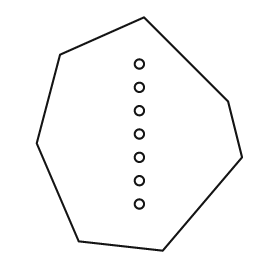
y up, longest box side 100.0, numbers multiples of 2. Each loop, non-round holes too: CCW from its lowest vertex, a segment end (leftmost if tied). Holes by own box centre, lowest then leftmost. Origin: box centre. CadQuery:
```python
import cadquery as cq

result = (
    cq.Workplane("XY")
    .moveTo(10.0, -50.0)
    .lineTo(44.0, -10.0)
    .lineTo(38.0, 14.0)
    .lineTo(2.0, 50.0)
    .lineTo(-34.0, 34.0)
    .lineTo(-44.0, -4.0)
    .lineTo(-26.0, -46.0)
    .close()
    .moveTo(0.0, -30.0)
    .circle(2.0)
    .moveTo(0.0, -20.0)
    .circle(2.0)
    .moveTo(0.0, -10.0)
    .circle(2.0)
    .moveTo(0.0, 0.0)
    .circle(2.0)
    .moveTo(0.0, 10.0)
    .circle(2.0)
    .moveTo(0.0, 20.0)
    .circle(2.0)
    .moveTo(0.0, 30.0)
    .circle(2.0)
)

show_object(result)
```